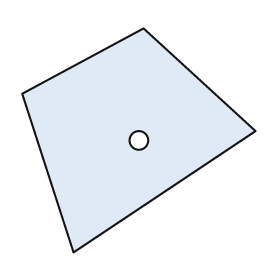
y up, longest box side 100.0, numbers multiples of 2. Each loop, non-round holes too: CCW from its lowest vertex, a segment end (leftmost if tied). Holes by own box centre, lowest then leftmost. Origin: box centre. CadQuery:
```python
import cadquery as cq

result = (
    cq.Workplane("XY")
    .moveTo(-28.0, -48.0)
    .lineTo(50.0, 4.0)
    .lineTo(2.0, 48.0)
    .lineTo(-50.0, 20.0)
    .close()
    .moveTo(0.0, 0.0)
    .circle(4.0)
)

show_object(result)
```